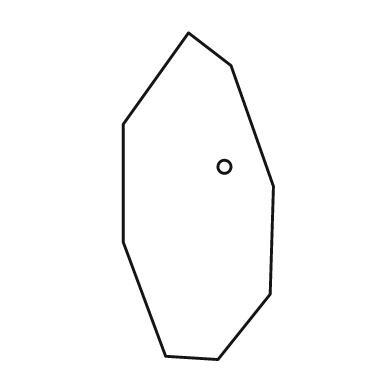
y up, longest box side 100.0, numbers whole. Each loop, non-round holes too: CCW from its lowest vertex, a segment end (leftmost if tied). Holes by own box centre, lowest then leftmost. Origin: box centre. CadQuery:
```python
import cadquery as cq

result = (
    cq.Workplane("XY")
    .moveTo(6.0, -50.0)
    .lineTo(22.0, -30.0)
    .lineTo(23.0, 3.0)
    .lineTo(10.0, 40.0)
    .lineTo(-3.0, 50.0)
    .lineTo(-23.0, 22.0)
    .lineTo(-23.0, -14.0)
    .lineTo(-10.0, -49.0)
    .close()
    .moveTo(8.0, 9.0)
    .circle(2.0)
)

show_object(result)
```